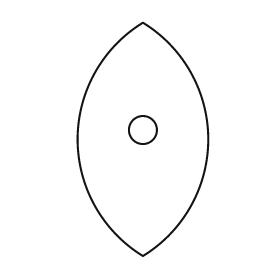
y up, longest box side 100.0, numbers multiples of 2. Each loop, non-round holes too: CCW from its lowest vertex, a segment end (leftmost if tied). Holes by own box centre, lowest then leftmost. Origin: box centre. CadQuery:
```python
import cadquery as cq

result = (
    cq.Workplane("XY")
    .moveTo(0.0, -50.0)
    .threePointArc((28.0, 0.0), (0.0, 50.0))
    .threePointArc((-28.0, 0.0), (0.0, -50.0))
    .close()
    .moveTo(0.0, 4.0)
    .circle(6.0)
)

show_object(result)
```